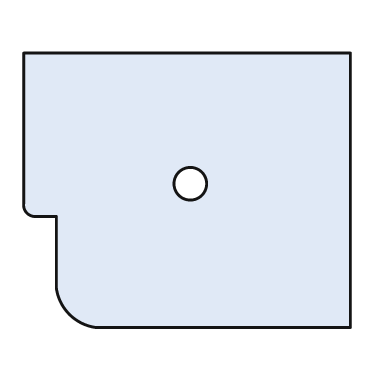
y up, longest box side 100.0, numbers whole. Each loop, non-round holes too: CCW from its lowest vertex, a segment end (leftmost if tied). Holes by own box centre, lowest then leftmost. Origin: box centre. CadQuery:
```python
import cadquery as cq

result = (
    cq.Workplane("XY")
    .moveTo(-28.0, -42.0)
    .lineTo(50.0, -42.0)
    .lineTo(50.0, 42.0)
    .lineTo(-50.0, 42.0)
    .lineTo(-50.0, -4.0)
    .threePointArc((-49.0, -7.0), (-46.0, -8.0))
    .lineTo(-40.0, -8.0)
    .lineTo(-40.0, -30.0)
    .threePointArc((-36.0, -38.0), (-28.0, -42.0))
    .close()
    .moveTo(1.0, 2.0)
    .circle(5.0)
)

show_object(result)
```